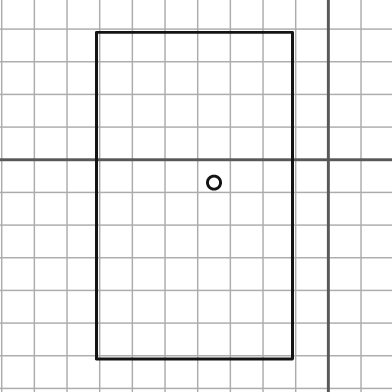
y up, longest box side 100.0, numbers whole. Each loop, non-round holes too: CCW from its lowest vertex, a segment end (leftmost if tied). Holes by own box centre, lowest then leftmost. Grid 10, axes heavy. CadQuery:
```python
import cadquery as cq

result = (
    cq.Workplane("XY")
    .moveTo(-71.0, -61.0)
    .lineTo(-11.0, -61.0)
    .lineTo(-11.0, 39.0)
    .lineTo(-71.0, 39.0)
    .close()
    .moveTo(-35.0, -7.0)
    .circle(2.0)
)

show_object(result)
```